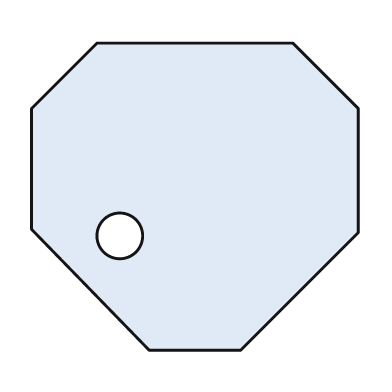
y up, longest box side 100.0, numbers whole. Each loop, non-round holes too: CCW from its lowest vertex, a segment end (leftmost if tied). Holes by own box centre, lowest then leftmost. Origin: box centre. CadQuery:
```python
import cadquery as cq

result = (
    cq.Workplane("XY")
    .moveTo(-14.0, -47.0)
    .lineTo(14.0, -47.0)
    .lineTo(50.0, -11.0)
    .lineTo(50.0, 27.0)
    .lineTo(30.0, 47.0)
    .lineTo(-30.0, 47.0)
    .lineTo(-50.0, 27.0)
    .lineTo(-50.0, -10.0)
    .close()
    .moveTo(-23.0, -12.0)
    .circle(7.0)
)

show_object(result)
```